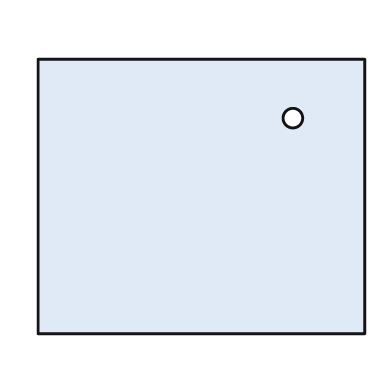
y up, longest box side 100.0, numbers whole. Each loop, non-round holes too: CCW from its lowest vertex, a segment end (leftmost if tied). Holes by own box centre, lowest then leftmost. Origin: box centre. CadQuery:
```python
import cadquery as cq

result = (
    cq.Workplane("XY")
    .moveTo(-50.0, -42.0)
    .lineTo(50.0, -42.0)
    .lineTo(50.0, 42.0)
    .lineTo(-50.0, 42.0)
    .close()
    .moveTo(28.0, 24.0)
    .circle(3.0)
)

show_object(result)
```